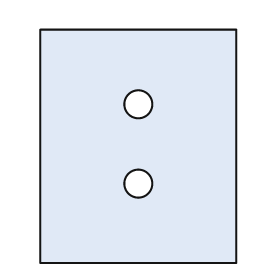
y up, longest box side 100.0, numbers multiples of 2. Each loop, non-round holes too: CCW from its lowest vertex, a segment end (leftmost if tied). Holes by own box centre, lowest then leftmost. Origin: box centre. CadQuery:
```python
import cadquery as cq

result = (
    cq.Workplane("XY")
    .moveTo(-42.0, -50.0)
    .lineTo(42.0, -50.0)
    .lineTo(42.0, 50.0)
    .lineTo(-42.0, 50.0)
    .close()
    .moveTo(0.0, -16.0)
    .circle(6.0)
    .moveTo(0.0, 18.0)
    .circle(6.0)
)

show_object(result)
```